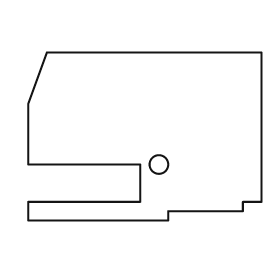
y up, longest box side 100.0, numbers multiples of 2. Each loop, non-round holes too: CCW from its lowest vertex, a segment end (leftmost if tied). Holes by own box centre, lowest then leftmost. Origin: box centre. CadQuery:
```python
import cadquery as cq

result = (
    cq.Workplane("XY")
    .moveTo(-50.0, -36.0)
    .lineTo(10.0, -36.0)
    .lineTo(10.0, -32.0)
    .lineTo(42.0, -32.0)
    .lineTo(42.0, -28.0)
    .lineTo(50.0, -28.0)
    .lineTo(50.0, 36.0)
    .lineTo(-42.0, 36.0)
    .lineTo(-50.0, 14.0)
    .lineTo(-50.0, -12.0)
    .lineTo(-2.0, -12.0)
    .lineTo(-2.0, -28.0)
    .lineTo(-50.0, -28.0)
    .close()
    .moveTo(6.0, -12.0)
    .circle(4.0)
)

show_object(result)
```